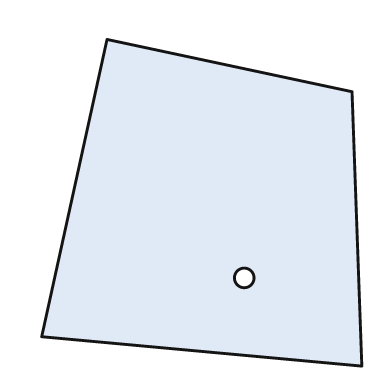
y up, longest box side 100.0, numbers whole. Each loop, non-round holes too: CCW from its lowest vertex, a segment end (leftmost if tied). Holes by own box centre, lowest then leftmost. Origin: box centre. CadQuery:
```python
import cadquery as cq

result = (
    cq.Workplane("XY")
    .moveTo(49.0, -50.0)
    .lineTo(46.0, 34.0)
    .lineTo(-29.0, 50.0)
    .lineTo(-49.0, -41.0)
    .close()
    .moveTo(13.0, -23.0)
    .circle(3.0)
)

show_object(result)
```